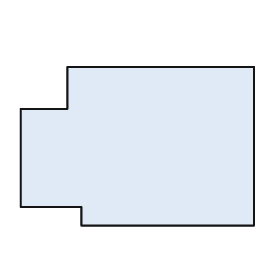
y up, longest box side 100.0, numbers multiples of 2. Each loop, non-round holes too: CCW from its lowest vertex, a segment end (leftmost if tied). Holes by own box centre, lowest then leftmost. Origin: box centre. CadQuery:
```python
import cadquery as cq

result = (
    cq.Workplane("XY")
    .moveTo(-24.0, -34.0)
    .lineTo(50.0, -34.0)
    .lineTo(50.0, 34.0)
    .lineTo(-30.0, 34.0)
    .lineTo(-30.0, 16.0)
    .lineTo(-50.0, 16.0)
    .lineTo(-50.0, -26.0)
    .lineTo(-24.0, -26.0)
    .close()
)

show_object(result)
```